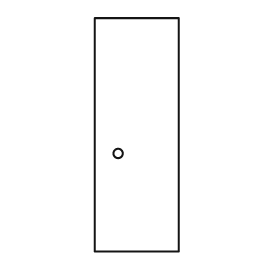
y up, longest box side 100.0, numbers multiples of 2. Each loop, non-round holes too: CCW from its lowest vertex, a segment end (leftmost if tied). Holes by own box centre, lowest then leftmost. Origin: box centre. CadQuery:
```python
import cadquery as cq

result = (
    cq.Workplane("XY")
    .moveTo(-18.0, -50.0)
    .lineTo(18.0, -50.0)
    .lineTo(18.0, 50.0)
    .lineTo(-18.0, 50.0)
    .close()
    .moveTo(-8.0, -8.0)
    .circle(2.0)
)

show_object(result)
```